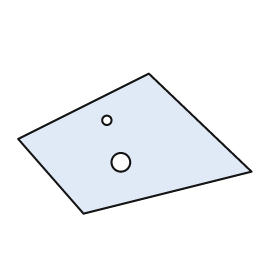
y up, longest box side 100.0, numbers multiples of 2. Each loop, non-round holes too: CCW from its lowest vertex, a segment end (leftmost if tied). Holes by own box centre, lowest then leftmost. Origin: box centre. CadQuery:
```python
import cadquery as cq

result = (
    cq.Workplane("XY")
    .moveTo(-22.0, -30.0)
    .lineTo(50.0, -12.0)
    .lineTo(6.0, 30.0)
    .lineTo(-50.0, 2.0)
    .close()
    .moveTo(-6.0, -8.0)
    .circle(4.0)
    .moveTo(-12.0, 10.0)
    .circle(2.0)
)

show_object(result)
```